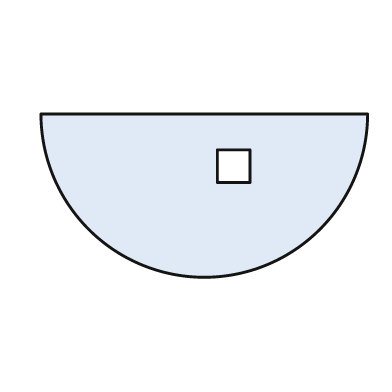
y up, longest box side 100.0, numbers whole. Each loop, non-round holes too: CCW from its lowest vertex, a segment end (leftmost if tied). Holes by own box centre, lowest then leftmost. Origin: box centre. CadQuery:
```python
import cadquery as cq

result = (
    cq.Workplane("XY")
    .moveTo(-50.0, 25.0)
    .threePointArc((0.0, -25.0), (50.0, 25.0))
    .close()
    .moveTo(4.0, 4.0)
    .lineTo(14.0, 4.0)
    .lineTo(14.0, 14.0)
    .lineTo(4.0, 14.0)
    .close()
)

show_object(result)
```